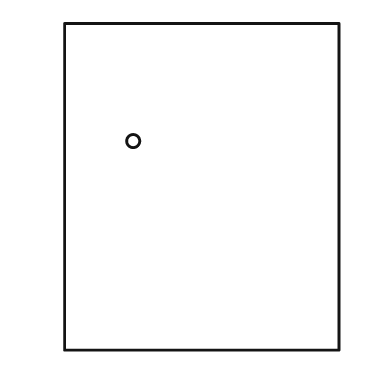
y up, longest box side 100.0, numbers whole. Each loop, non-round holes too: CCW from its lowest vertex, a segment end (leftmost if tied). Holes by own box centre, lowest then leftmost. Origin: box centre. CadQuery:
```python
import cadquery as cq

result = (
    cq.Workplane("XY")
    .moveTo(-42.0, -50.0)
    .lineTo(42.0, -50.0)
    .lineTo(42.0, 50.0)
    .lineTo(-42.0, 50.0)
    .close()
    .moveTo(-21.0, 14.0)
    .circle(2.0)
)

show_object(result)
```